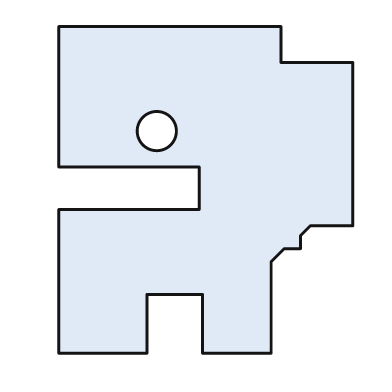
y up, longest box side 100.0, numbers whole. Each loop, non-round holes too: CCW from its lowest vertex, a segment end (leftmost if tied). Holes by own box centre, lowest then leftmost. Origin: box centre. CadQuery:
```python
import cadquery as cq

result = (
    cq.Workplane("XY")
    .moveTo(-45.0, -50.0)
    .lineTo(-18.0, -50.0)
    .lineTo(-18.0, -32.0)
    .lineTo(-1.0, -32.0)
    .lineTo(-1.0, -50.0)
    .lineTo(20.0, -50.0)
    .lineTo(20.0, -22.0)
    .lineTo(24.0, -18.0)
    .lineTo(29.0, -18.0)
    .lineTo(29.0, -14.0)
    .lineTo(32.0, -11.0)
    .lineTo(45.0, -11.0)
    .lineTo(45.0, 39.0)
    .lineTo(23.0, 39.0)
    .lineTo(23.0, 50.0)
    .lineTo(-45.0, 50.0)
    .lineTo(-45.0, 7.0)
    .lineTo(-2.0, 7.0)
    .lineTo(-2.0, -6.0)
    .lineTo(-45.0, -6.0)
    .close()
    .moveTo(-15.0, 18.0)
    .circle(6.0)
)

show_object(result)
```